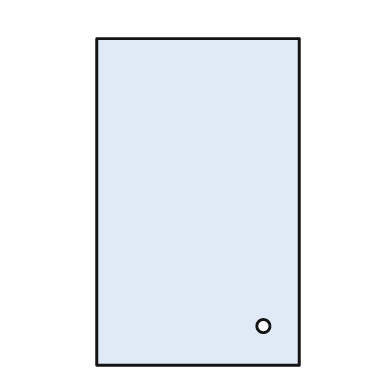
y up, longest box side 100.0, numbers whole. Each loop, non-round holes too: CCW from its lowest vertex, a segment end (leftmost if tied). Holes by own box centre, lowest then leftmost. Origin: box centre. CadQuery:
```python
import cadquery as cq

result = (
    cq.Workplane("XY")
    .moveTo(-31.0, -50.0)
    .lineTo(31.0, -50.0)
    .lineTo(31.0, 50.0)
    .lineTo(-31.0, 50.0)
    .close()
    .moveTo(20.0, -38.0)
    .circle(2.0)
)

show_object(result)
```